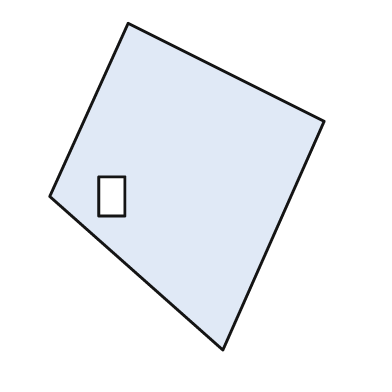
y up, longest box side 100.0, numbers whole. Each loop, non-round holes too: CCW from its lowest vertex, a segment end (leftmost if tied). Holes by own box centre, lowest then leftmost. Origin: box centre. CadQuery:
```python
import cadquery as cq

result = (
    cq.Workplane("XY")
    .moveTo(11.0, -50.0)
    .lineTo(42.0, 20.0)
    .lineTo(-18.0, 50.0)
    .lineTo(-42.0, -3.0)
    .close()
    .moveTo(-27.0, -9.0)
    .lineTo(-19.0, -9.0)
    .lineTo(-19.0, 3.0)
    .lineTo(-27.0, 3.0)
    .close()
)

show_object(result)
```